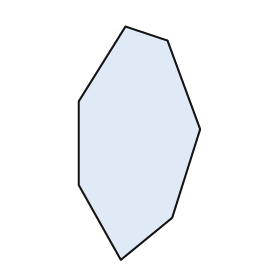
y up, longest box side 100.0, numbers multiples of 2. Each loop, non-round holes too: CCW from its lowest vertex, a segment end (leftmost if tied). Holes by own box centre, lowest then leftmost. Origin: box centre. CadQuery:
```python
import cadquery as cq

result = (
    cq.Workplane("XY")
    .moveTo(-8.0, -50.0)
    .lineTo(14.0, -32.0)
    .lineTo(26.0, 6.0)
    .lineTo(12.0, 44.0)
    .lineTo(-6.0, 50.0)
    .lineTo(-26.0, 18.0)
    .lineTo(-26.0, -18.0)
    .close()
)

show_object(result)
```